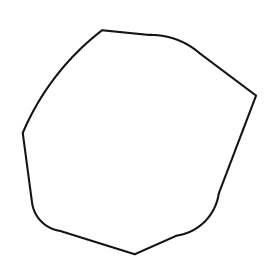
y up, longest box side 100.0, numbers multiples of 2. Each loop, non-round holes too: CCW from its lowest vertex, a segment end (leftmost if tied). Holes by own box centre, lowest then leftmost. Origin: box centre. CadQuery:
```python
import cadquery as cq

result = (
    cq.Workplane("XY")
    .moveTo(-2.0, -48.0)
    .lineTo(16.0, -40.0)
    .threePointArc((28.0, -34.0), (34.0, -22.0))
    .lineTo(50.0, 20.0)
    .lineTo(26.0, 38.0)
    .threePointArc((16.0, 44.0), (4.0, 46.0))
    .lineTo(-16.0, 48.0)
    .threePointArc((-36.0, 28.0), (-50.0, 4.0))
    .lineTo(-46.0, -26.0)
    .threePointArc((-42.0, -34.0), (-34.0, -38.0))
    .close()
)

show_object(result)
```